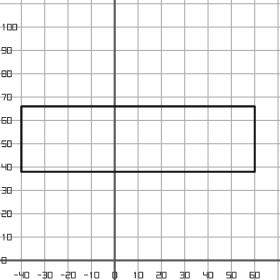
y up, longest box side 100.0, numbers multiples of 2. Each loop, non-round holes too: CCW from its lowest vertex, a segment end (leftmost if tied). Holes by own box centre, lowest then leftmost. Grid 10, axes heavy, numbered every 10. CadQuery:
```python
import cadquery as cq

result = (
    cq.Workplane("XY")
    .moveTo(-40.0, 38.0)
    .lineTo(60.0, 38.0)
    .lineTo(60.0, 66.0)
    .lineTo(-40.0, 66.0)
    .close()
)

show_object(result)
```